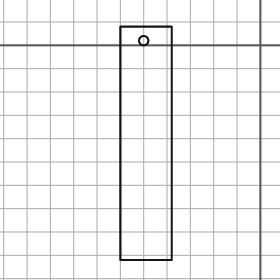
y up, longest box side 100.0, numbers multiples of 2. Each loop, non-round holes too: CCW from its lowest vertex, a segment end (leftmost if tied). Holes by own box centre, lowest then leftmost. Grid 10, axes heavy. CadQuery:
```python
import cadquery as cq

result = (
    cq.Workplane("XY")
    .moveTo(-60.0, -92.0)
    .lineTo(-38.0, -92.0)
    .lineTo(-38.0, 8.0)
    .lineTo(-60.0, 8.0)
    .close()
    .moveTo(-50.0, 2.0)
    .circle(2.0)
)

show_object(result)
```